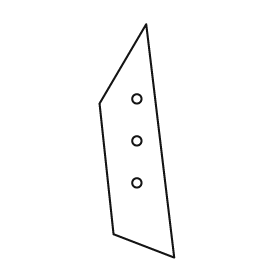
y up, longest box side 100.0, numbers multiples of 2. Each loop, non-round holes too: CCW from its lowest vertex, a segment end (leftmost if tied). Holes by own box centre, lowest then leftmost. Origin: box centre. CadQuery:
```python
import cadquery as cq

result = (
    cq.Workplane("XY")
    .moveTo(16.0, -50.0)
    .lineTo(4.0, 50.0)
    .lineTo(-16.0, 16.0)
    .lineTo(-10.0, -40.0)
    .close()
    .moveTo(0.0, -18.0)
    .circle(2.0)
    .moveTo(0.0, 0.0)
    .circle(2.0)
    .moveTo(0.0, 18.0)
    .circle(2.0)
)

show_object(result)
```